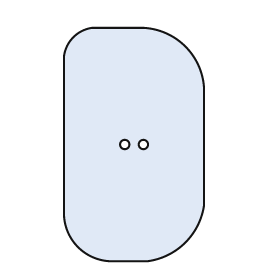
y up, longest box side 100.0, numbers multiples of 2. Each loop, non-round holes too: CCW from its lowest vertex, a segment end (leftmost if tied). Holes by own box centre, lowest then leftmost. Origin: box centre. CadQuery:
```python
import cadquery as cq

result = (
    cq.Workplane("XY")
    .moveTo(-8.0, -50.0)
    .lineTo(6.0, -50.0)
    .threePointArc((22.0, -42.0), (30.0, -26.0))
    .lineTo(30.0, 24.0)
    .threePointArc((22.0, 42.0), (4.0, 50.0))
    .lineTo(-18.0, 50.0)
    .threePointArc((-26.0, 46.0), (-30.0, 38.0))
    .lineTo(-30.0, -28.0)
    .threePointArc((-24.0, -44.0), (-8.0, -50.0))
    .close()
    .moveTo(-4.0, 0.0)
    .circle(2.0)
    .moveTo(4.0, 0.0)
    .circle(2.0)
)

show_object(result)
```